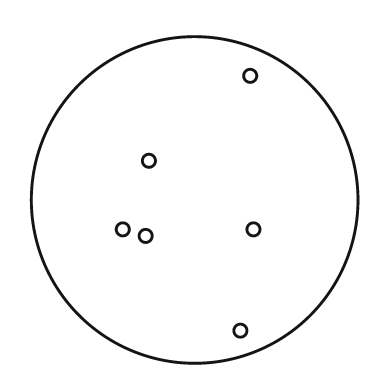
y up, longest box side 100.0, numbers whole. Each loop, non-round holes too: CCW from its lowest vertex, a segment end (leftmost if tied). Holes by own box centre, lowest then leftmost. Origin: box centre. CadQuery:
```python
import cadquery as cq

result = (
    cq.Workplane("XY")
    .moveTo(0.0, 0.0)
    .circle(50.0)
    .moveTo(14.0, -40.0)
    .circle(2.0)
    .moveTo(-15.0, -11.0)
    .circle(2.0)
    .moveTo(-22.0, -9.0)
    .circle(2.0)
    .moveTo(18.0, -9.0)
    .circle(2.0)
    .moveTo(-14.0, 12.0)
    .circle(2.0)
    .moveTo(17.0, 38.0)
    .circle(2.0)
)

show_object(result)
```